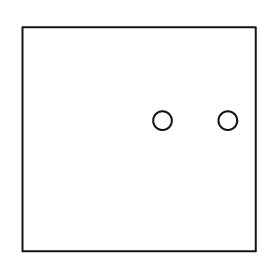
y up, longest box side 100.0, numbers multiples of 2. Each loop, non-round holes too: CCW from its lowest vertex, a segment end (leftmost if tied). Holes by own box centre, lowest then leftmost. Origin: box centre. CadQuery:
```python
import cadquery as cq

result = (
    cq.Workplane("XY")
    .moveTo(-50.0, -48.0)
    .lineTo(50.0, -48.0)
    .lineTo(50.0, 48.0)
    .lineTo(-50.0, 48.0)
    .close()
    .moveTo(10.0, 8.0)
    .circle(4.0)
    .moveTo(38.0, 8.0)
    .circle(4.0)
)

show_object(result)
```